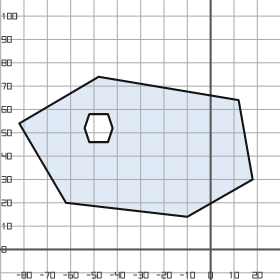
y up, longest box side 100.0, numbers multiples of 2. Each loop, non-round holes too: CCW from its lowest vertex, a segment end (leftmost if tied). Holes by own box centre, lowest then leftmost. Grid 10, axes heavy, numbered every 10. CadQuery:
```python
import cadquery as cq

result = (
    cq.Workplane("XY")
    .moveTo(-10.0, 14.0)
    .lineTo(18.0, 30.0)
    .lineTo(12.0, 64.0)
    .lineTo(-48.0, 74.0)
    .lineTo(-82.0, 54.0)
    .lineTo(-62.0, 20.0)
    .close()
    .moveTo(-52.0, 46.0)
    .lineTo(-44.0, 46.0)
    .lineTo(-42.0, 52.0)
    .lineTo(-44.0, 58.0)
    .lineTo(-52.0, 58.0)
    .lineTo(-54.0, 52.0)
    .close()
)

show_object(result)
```